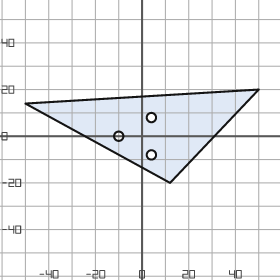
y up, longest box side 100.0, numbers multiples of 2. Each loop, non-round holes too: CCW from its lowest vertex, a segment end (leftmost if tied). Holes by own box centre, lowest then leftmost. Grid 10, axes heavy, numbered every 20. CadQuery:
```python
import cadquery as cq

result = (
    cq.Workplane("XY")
    .moveTo(12.0, -20.0)
    .lineTo(50.0, 20.0)
    .lineTo(-50.0, 14.0)
    .close()
    .moveTo(4.0, -8.0)
    .circle(2.0)
    .moveTo(-10.0, 0.0)
    .circle(2.0)
    .moveTo(4.0, 8.0)
    .circle(2.0)
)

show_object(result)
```